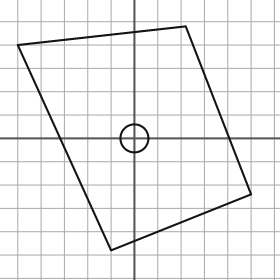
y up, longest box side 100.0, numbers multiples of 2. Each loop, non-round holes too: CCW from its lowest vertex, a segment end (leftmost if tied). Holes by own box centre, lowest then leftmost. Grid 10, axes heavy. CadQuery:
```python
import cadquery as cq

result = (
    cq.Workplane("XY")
    .moveTo(-10.0, -48.0)
    .lineTo(50.0, -24.0)
    .lineTo(22.0, 48.0)
    .lineTo(-50.0, 40.0)
    .close()
    .moveTo(0.0, 0.0)
    .circle(6.0)
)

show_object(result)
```